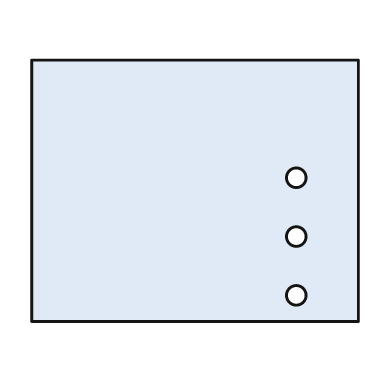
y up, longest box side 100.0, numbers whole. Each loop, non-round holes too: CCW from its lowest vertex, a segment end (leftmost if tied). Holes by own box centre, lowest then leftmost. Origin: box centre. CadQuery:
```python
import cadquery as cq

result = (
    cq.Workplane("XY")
    .moveTo(-50.0, -40.0)
    .lineTo(50.0, -40.0)
    .lineTo(50.0, 40.0)
    .lineTo(-50.0, 40.0)
    .close()
    .moveTo(31.0, -32.0)
    .circle(3.0)
    .moveTo(31.0, -14.0)
    .circle(3.0)
    .moveTo(31.0, 4.0)
    .circle(3.0)
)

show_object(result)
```